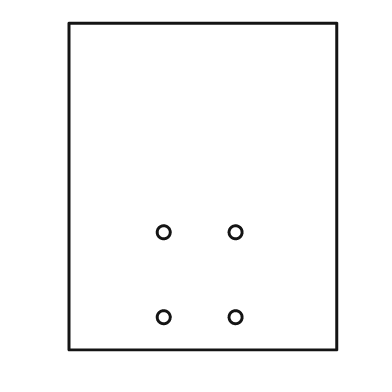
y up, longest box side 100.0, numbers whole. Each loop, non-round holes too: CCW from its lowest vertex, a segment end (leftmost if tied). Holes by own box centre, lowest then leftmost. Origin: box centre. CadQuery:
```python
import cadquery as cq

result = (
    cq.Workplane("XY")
    .moveTo(-41.0, -50.0)
    .lineTo(41.0, -50.0)
    .lineTo(41.0, 50.0)
    .lineTo(-41.0, 50.0)
    .close()
    .moveTo(-12.0, -40.0)
    .circle(2.0)
    .moveTo(10.0, -40.0)
    .circle(2.0)
    .moveTo(-12.0, -14.0)
    .circle(2.0)
    .moveTo(10.0, -14.0)
    .circle(2.0)
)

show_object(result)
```